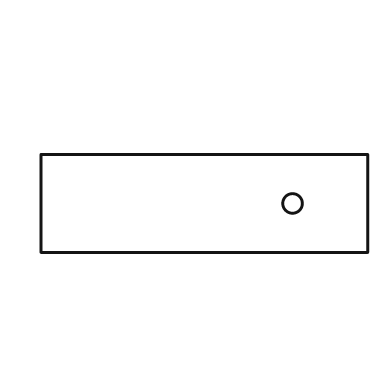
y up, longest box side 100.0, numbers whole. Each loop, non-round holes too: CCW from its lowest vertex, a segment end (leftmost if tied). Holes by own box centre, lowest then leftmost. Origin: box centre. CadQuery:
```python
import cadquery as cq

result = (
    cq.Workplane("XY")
    .moveTo(-50.0, -15.0)
    .lineTo(50.0, -15.0)
    .lineTo(50.0, 15.0)
    .lineTo(-50.0, 15.0)
    .close()
    .moveTo(27.0, 0.0)
    .circle(3.0)
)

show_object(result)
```